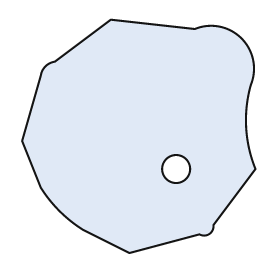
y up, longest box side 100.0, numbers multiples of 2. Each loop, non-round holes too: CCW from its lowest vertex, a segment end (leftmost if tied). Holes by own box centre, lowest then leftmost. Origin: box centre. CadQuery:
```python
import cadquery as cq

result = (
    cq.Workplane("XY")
    .moveTo(-4.0, -50.0)
    .lineTo(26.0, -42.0)
    .threePointArc((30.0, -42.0), (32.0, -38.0))
    .lineTo(50.0, -14.0)
    .threePointArc((46.0, 4.0), (48.0, 22.0))
    .threePointArc((44.0, 42.0), (24.0, 46.0))
    .lineTo(-12.0, 50.0)
    .lineTo(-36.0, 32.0)
    .threePointArc((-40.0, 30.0), (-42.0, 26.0))
    .lineTo(-50.0, -2.0)
    .lineTo(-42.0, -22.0)
    .threePointArc((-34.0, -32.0), (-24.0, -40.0))
    .close()
    .moveTo(16.0, -14.0)
    .circle(6.0)
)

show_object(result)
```